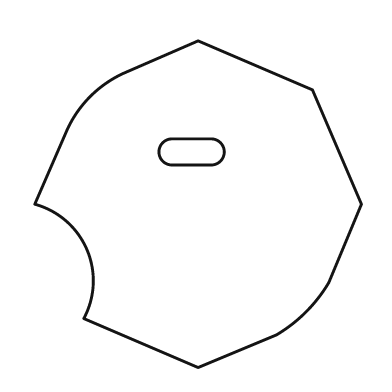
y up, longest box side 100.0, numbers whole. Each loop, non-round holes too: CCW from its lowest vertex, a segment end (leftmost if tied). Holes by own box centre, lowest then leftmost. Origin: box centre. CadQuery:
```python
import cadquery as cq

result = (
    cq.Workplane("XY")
    .moveTo(0.0, -50.0)
    .lineTo(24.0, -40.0)
    .threePointArc((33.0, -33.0), (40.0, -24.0))
    .lineTo(50.0, 0.0)
    .lineTo(35.0, 35.0)
    .lineTo(0.0, 50.0)
    .lineTo(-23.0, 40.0)
    .threePointArc((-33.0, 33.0), (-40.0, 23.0))
    .lineTo(-50.0, 0.0)
    .threePointArc((-34.0, -14.0), (-35.0, -35.0))
    .close()
    .moveTo(-8.0, 12.0)
    .lineTo(4.0, 12.0)
    .threePointArc((8.0, 16.0), (4.0, 20.0))
    .lineTo(-8.0, 20.0)
    .threePointArc((-12.0, 16.0), (-8.0, 12.0))
    .close()
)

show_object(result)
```